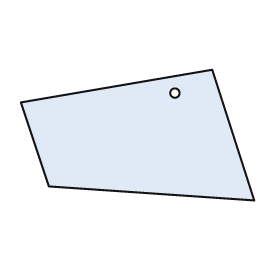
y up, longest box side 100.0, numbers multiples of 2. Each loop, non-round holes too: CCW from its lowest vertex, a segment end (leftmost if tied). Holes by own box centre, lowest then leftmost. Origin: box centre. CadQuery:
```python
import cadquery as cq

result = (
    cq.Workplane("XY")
    .moveTo(50.0, -28.0)
    .lineTo(32.0, 28.0)
    .lineTo(-50.0, 14.0)
    .lineTo(-38.0, -22.0)
    .close()
    .moveTo(16.0, 18.0)
    .circle(2.0)
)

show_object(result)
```